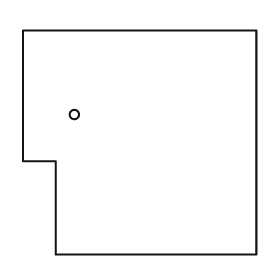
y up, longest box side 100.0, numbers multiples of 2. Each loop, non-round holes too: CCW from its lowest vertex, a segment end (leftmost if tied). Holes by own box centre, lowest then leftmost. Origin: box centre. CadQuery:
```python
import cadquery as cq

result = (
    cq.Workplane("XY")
    .moveTo(-36.0, -48.0)
    .lineTo(50.0, -48.0)
    .lineTo(50.0, 48.0)
    .lineTo(-50.0, 48.0)
    .lineTo(-50.0, -8.0)
    .lineTo(-36.0, -8.0)
    .close()
    .moveTo(-28.0, 12.0)
    .circle(2.0)
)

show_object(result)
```